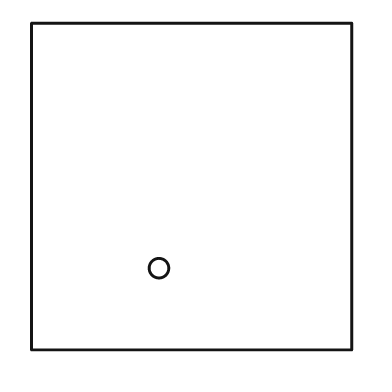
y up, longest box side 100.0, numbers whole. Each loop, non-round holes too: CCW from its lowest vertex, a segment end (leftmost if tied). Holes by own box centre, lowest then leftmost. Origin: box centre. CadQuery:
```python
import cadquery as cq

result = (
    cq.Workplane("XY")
    .moveTo(-49.0, -50.0)
    .lineTo(49.0, -50.0)
    .lineTo(49.0, 50.0)
    .lineTo(-49.0, 50.0)
    .close()
    .moveTo(-10.0, -25.0)
    .circle(3.0)
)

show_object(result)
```